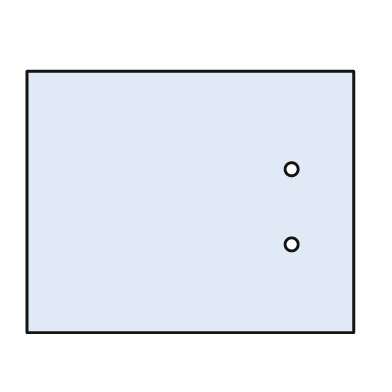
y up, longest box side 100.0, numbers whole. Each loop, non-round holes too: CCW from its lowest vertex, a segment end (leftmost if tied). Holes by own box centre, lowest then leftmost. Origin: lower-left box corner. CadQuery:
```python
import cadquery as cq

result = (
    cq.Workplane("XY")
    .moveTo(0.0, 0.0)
    .lineTo(100.0, 0.0)
    .lineTo(100.0, 80.0)
    .lineTo(0.0, 80.0)
    .close()
    .moveTo(81.0, 27.0)
    .circle(2.0)
    .moveTo(81.0, 50.0)
    .circle(2.0)
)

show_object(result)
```